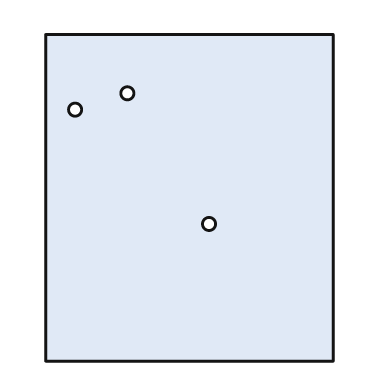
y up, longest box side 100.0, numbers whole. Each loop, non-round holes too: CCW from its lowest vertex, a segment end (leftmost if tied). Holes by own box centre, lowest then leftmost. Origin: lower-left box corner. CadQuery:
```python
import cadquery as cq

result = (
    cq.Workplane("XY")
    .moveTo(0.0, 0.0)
    .lineTo(88.0, 0.0)
    .lineTo(88.0, 100.0)
    .lineTo(0.0, 100.0)
    .close()
    .moveTo(50.0, 42.0)
    .circle(2.0)
    .moveTo(9.0, 77.0)
    .circle(2.0)
    .moveTo(25.0, 82.0)
    .circle(2.0)
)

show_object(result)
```